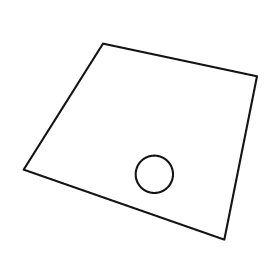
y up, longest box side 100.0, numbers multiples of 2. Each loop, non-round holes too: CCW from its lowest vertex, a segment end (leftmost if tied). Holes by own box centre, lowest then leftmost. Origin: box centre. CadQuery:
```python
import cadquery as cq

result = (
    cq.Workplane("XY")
    .moveTo(36.0, -42.0)
    .lineTo(50.0, 28.0)
    .lineTo(-16.0, 42.0)
    .lineTo(-50.0, -12.0)
    .close()
    .moveTo(6.0, -14.0)
    .circle(8.0)
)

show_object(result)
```